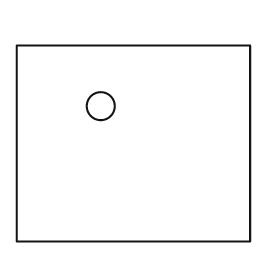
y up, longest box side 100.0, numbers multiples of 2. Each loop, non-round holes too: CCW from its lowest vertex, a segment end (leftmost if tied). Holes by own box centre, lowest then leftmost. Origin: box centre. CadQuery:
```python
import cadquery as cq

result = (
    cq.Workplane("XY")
    .moveTo(-50.0, -42.0)
    .lineTo(50.0, -42.0)
    .lineTo(50.0, 42.0)
    .lineTo(-50.0, 42.0)
    .close()
    .moveTo(-14.0, 16.0)
    .circle(6.0)
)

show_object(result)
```